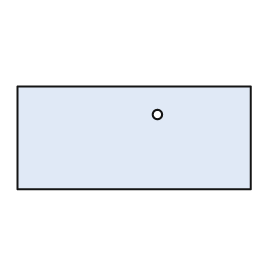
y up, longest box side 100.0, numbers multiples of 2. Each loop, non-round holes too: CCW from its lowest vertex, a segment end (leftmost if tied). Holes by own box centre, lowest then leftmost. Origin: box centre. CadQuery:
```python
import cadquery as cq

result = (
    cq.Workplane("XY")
    .moveTo(-50.0, -22.0)
    .lineTo(50.0, -22.0)
    .lineTo(50.0, 22.0)
    .lineTo(-50.0, 22.0)
    .close()
    .moveTo(10.0, 10.0)
    .circle(2.0)
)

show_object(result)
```